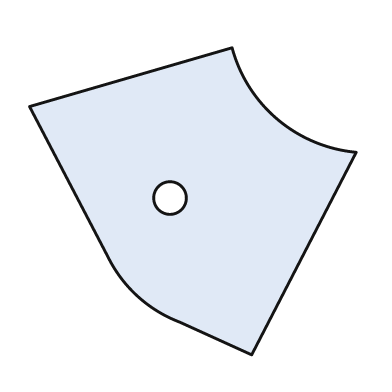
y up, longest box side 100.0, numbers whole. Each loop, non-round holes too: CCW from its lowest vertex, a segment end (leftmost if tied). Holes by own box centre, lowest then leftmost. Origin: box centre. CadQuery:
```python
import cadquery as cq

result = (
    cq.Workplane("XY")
    .moveTo(18.0, -47.0)
    .lineTo(50.0, 15.0)
    .threePointArc((26.0, 25.0), (12.0, 47.0))
    .lineTo(-50.0, 29.0)
    .lineTo(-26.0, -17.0)
    .threePointArc((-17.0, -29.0), (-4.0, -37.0))
    .close()
    .moveTo(-7.0, 1.0)
    .circle(5.0)
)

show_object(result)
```